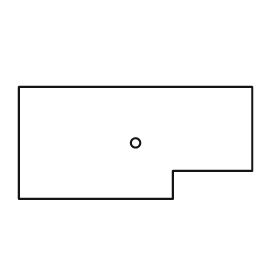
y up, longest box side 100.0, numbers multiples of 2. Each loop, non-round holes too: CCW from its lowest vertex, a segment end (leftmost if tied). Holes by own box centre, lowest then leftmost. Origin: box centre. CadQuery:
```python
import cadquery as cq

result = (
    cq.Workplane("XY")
    .moveTo(-50.0, -24.0)
    .lineTo(16.0, -24.0)
    .lineTo(16.0, -12.0)
    .lineTo(50.0, -12.0)
    .lineTo(50.0, 24.0)
    .lineTo(-50.0, 24.0)
    .close()
    .moveTo(0.0, 0.0)
    .circle(2.0)
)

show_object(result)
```